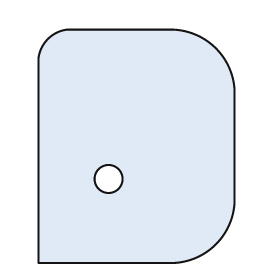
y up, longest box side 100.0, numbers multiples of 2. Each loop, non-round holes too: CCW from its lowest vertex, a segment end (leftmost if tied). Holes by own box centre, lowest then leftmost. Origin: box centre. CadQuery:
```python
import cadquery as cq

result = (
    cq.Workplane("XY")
    .moveTo(-42.0, -50.0)
    .lineTo(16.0, -50.0)
    .threePointArc((34.0, -42.0), (42.0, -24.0))
    .lineTo(42.0, 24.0)
    .threePointArc((34.0, 42.0), (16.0, 50.0))
    .lineTo(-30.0, 50.0)
    .threePointArc((-38.0, 46.0), (-42.0, 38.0))
    .close()
    .moveTo(-12.0, -14.0)
    .circle(6.0)
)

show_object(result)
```